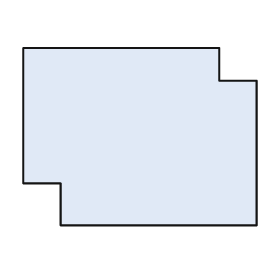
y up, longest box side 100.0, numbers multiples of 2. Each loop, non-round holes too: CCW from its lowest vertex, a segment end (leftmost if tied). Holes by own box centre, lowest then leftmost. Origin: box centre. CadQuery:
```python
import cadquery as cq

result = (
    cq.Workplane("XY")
    .moveTo(-34.0, -38.0)
    .lineTo(50.0, -38.0)
    .lineTo(50.0, 24.0)
    .lineTo(34.0, 24.0)
    .lineTo(34.0, 38.0)
    .lineTo(-50.0, 38.0)
    .lineTo(-50.0, -20.0)
    .lineTo(-34.0, -20.0)
    .close()
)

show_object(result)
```